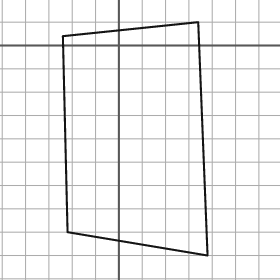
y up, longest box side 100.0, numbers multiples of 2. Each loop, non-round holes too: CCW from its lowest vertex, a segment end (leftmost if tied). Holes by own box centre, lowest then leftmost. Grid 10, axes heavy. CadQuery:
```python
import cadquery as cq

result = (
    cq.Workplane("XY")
    .moveTo(38.0, -90.0)
    .lineTo(34.0, 10.0)
    .lineTo(-24.0, 4.0)
    .lineTo(-22.0, -80.0)
    .close()
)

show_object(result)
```